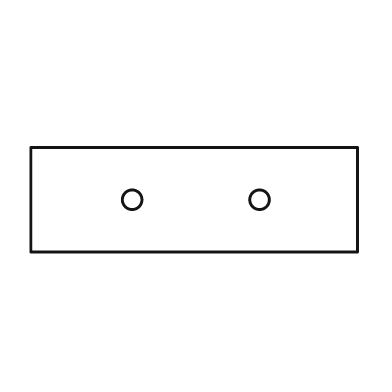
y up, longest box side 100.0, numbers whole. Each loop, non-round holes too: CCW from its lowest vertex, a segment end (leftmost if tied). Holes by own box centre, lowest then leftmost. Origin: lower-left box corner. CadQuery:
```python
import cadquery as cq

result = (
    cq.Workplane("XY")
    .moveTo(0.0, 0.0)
    .lineTo(100.0, 0.0)
    .lineTo(100.0, 32.0)
    .lineTo(0.0, 32.0)
    .close()
    .moveTo(31.0, 16.0)
    .circle(3.0)
    .moveTo(70.0, 16.0)
    .circle(3.0)
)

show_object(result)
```